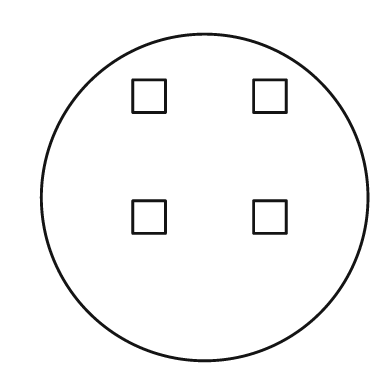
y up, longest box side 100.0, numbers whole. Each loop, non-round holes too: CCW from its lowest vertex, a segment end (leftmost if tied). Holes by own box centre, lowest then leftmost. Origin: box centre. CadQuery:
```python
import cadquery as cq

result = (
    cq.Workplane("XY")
    .moveTo(0.0, 0.0)
    .circle(50.0)
    .moveTo(-22.0, -11.0)
    .lineTo(-12.0, -11.0)
    .lineTo(-12.0, -1.0)
    .lineTo(-22.0, -1.0)
    .close()
    .moveTo(15.0, -11.0)
    .lineTo(25.0, -11.0)
    .lineTo(25.0, -1.0)
    .lineTo(15.0, -1.0)
    .close()
    .moveTo(-22.0, 26.0)
    .lineTo(-12.0, 26.0)
    .lineTo(-12.0, 36.0)
    .lineTo(-22.0, 36.0)
    .close()
    .moveTo(15.0, 26.0)
    .lineTo(25.0, 26.0)
    .lineTo(25.0, 36.0)
    .lineTo(15.0, 36.0)
    .close()
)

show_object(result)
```